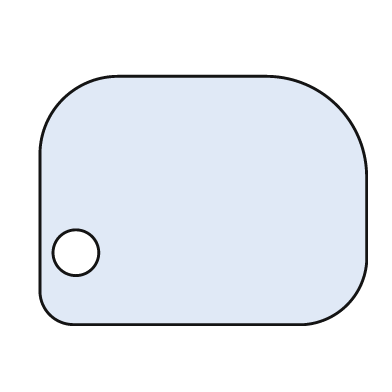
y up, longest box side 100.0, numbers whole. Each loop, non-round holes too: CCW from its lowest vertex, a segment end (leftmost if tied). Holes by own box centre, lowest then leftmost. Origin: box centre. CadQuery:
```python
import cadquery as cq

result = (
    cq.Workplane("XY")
    .moveTo(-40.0, -38.0)
    .lineTo(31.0, -38.0)
    .threePointArc((44.0, -32.0), (50.0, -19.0))
    .lineTo(50.0, 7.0)
    .threePointArc((41.0, 29.0), (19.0, 38.0))
    .lineTo(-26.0, 38.0)
    .threePointArc((-43.0, 31.0), (-50.0, 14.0))
    .lineTo(-50.0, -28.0)
    .threePointArc((-47.0, -35.0), (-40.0, -38.0))
    .close()
    .moveTo(-39.0, -16.0)
    .circle(7.0)
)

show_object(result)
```